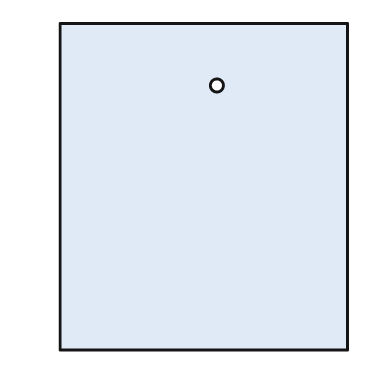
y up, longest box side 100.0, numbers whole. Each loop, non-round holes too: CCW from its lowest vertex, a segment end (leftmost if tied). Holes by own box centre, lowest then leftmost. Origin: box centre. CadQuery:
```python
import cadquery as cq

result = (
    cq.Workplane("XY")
    .moveTo(-44.0, -50.0)
    .lineTo(44.0, -50.0)
    .lineTo(44.0, 50.0)
    .lineTo(-44.0, 50.0)
    .close()
    .moveTo(4.0, 31.0)
    .circle(2.0)
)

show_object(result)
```